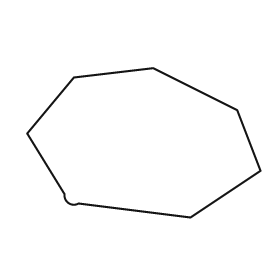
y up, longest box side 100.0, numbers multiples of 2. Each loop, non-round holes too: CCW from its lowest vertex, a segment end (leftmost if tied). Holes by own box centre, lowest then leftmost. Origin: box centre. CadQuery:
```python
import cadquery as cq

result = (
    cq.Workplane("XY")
    .moveTo(20.0, -32.0)
    .lineTo(50.0, -12.0)
    .lineTo(40.0, 14.0)
    .lineTo(4.0, 32.0)
    .lineTo(-30.0, 28.0)
    .lineTo(-50.0, 4.0)
    .lineTo(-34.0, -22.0)
    .threePointArc((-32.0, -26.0), (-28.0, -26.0))
    .close()
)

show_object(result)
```